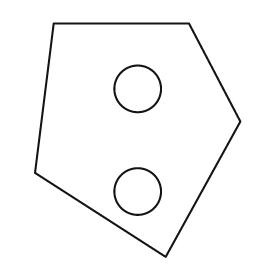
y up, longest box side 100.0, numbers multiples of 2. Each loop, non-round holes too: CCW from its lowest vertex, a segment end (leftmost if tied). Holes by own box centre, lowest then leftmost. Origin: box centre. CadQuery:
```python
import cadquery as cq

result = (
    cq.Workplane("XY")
    .moveTo(12.0, -50.0)
    .lineTo(44.0, 8.0)
    .lineTo(22.0, 50.0)
    .lineTo(-36.0, 50.0)
    .lineTo(-44.0, -14.0)
    .close()
    .moveTo(0.0, -22.0)
    .circle(10.0)
    .moveTo(0.0, 22.0)
    .circle(10.0)
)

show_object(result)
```